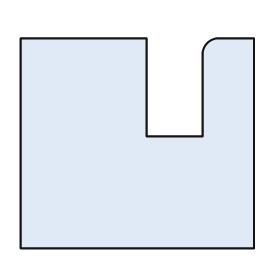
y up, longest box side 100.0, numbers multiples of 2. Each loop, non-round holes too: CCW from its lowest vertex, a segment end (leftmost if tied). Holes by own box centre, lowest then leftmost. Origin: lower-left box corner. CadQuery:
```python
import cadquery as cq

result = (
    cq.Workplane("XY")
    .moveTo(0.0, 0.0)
    .lineTo(100.0, 0.0)
    .lineTo(100.0, 90.0)
    .lineTo(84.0, 90.0)
    .threePointArc((80.0, 88.0), (78.0, 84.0))
    .lineTo(78.0, 48.0)
    .lineTo(54.0, 48.0)
    .lineTo(54.0, 90.0)
    .lineTo(0.0, 90.0)
    .close()
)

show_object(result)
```